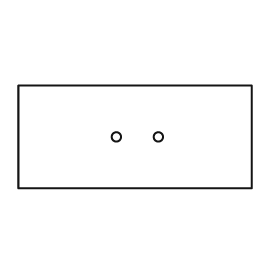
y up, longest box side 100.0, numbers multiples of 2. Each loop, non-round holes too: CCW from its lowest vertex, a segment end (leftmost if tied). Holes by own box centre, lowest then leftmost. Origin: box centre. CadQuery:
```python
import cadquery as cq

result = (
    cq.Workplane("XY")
    .moveTo(-50.0, -22.0)
    .lineTo(50.0, -22.0)
    .lineTo(50.0, 22.0)
    .lineTo(-50.0, 22.0)
    .close()
    .moveTo(-8.0, 0.0)
    .circle(2.0)
    .moveTo(10.0, 0.0)
    .circle(2.0)
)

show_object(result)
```